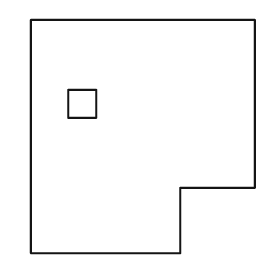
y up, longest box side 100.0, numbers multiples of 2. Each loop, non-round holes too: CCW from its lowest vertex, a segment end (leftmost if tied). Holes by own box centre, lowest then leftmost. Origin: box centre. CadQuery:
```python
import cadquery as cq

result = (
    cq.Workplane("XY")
    .moveTo(-48.0, -50.0)
    .lineTo(16.0, -50.0)
    .lineTo(16.0, -22.0)
    .lineTo(48.0, -22.0)
    .lineTo(48.0, 50.0)
    .lineTo(-48.0, 50.0)
    .close()
    .moveTo(-32.0, 8.0)
    .lineTo(-20.0, 8.0)
    .lineTo(-20.0, 20.0)
    .lineTo(-32.0, 20.0)
    .close()
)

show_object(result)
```